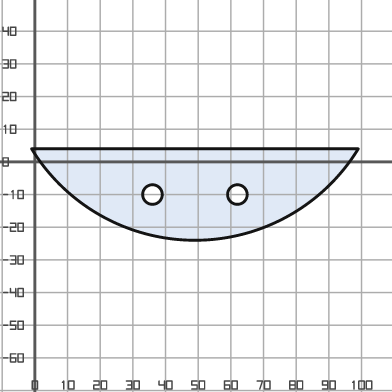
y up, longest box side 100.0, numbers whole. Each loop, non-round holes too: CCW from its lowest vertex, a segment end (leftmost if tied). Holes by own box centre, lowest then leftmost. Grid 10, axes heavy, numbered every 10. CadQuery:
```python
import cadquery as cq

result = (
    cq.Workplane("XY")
    .moveTo(-1.0, 4.0)
    .threePointArc((49.0, -24.0), (99.0, 4.0))
    .close()
    .moveTo(36.0, -10.0)
    .circle(3.0)
    .moveTo(62.0, -10.0)
    .circle(3.0)
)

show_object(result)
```